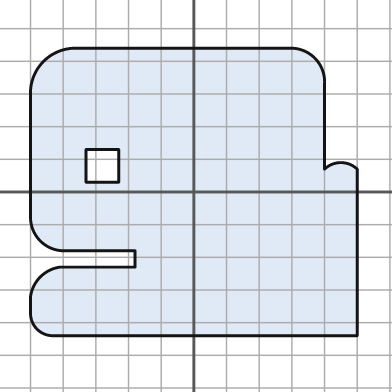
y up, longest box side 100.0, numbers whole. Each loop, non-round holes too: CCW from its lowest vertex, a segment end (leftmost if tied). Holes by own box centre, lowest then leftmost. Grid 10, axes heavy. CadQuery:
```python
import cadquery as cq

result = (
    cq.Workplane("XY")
    .moveTo(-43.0, -44.0)
    .lineTo(50.0, -44.0)
    .lineTo(50.0, 7.0)
    .threePointArc((45.0, 9.0), (40.0, 7.0))
    .lineTo(40.0, 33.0)
    .threePointArc((37.0, 41.0), (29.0, 44.0))
    .lineTo(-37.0, 44.0)
    .threePointArc((-46.0, 40.0), (-50.0, 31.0))
    .lineTo(-50.0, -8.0)
    .threePointArc((-47.0, -15.0), (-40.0, -18.0))
    .lineTo(-18.0, -18.0)
    .lineTo(-18.0, -23.0)
    .lineTo(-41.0, -23.0)
    .threePointArc((-47.0, -26.0), (-50.0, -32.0))
    .lineTo(-50.0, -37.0)
    .threePointArc((-48.0, -42.0), (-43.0, -44.0))
    .close()
    .moveTo(-33.0, 3.0)
    .lineTo(-23.0, 3.0)
    .lineTo(-23.0, 13.0)
    .lineTo(-33.0, 13.0)
    .close()
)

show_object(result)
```